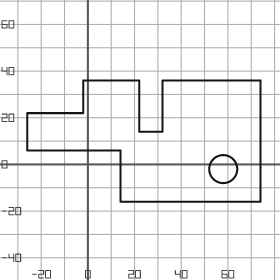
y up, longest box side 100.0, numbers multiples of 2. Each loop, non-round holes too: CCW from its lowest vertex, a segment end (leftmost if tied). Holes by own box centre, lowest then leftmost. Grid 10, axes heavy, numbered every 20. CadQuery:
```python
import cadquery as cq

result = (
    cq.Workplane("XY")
    .moveTo(14.0, -16.0)
    .lineTo(74.0, -16.0)
    .lineTo(74.0, 36.0)
    .lineTo(32.0, 36.0)
    .lineTo(32.0, 14.0)
    .lineTo(22.0, 14.0)
    .lineTo(22.0, 36.0)
    .lineTo(-2.0, 36.0)
    .lineTo(-2.0, 22.0)
    .lineTo(-26.0, 22.0)
    .lineTo(-26.0, 6.0)
    .lineTo(14.0, 6.0)
    .close()
    .moveTo(58.0, -2.0)
    .circle(6.0)
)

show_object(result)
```